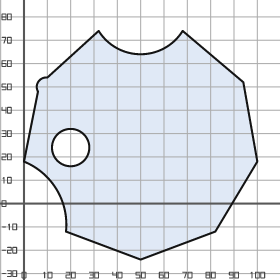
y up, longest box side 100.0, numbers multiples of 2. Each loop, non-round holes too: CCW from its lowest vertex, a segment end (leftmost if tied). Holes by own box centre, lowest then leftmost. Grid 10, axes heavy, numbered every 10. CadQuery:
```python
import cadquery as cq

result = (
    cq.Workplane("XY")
    .moveTo(50.0, -24.0)
    .lineTo(82.0, -12.0)
    .lineTo(100.0, 18.0)
    .lineTo(94.0, 52.0)
    .lineTo(68.0, 74.0)
    .threePointArc((50.0, 64.0), (32.0, 74.0))
    .lineTo(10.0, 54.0)
    .threePointArc((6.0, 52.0), (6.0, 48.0))
    .lineTo(0.0, 18.0)
    .threePointArc((14.0, 6.0), (18.0, -12.0))
    .close()
    .moveTo(20.0, 24.0)
    .circle(8.0)
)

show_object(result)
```